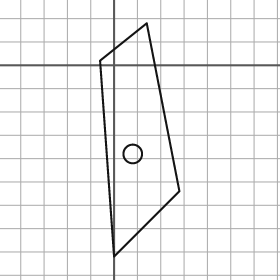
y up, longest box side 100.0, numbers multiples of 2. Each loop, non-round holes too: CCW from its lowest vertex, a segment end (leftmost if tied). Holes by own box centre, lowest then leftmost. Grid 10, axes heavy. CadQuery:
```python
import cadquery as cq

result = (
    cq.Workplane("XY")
    .moveTo(0.0, -82.0)
    .lineTo(28.0, -54.0)
    .lineTo(14.0, 18.0)
    .lineTo(-6.0, 2.0)
    .close()
    .moveTo(8.0, -38.0)
    .circle(4.0)
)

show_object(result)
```